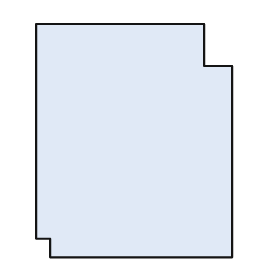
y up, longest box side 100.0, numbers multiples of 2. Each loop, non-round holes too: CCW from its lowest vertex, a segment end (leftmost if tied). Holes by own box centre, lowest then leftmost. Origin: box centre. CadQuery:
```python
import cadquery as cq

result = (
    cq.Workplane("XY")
    .moveTo(-36.0, -50.0)
    .lineTo(42.0, -50.0)
    .lineTo(42.0, 32.0)
    .lineTo(30.0, 32.0)
    .lineTo(30.0, 50.0)
    .lineTo(-42.0, 50.0)
    .lineTo(-42.0, -42.0)
    .lineTo(-36.0, -42.0)
    .close()
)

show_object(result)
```